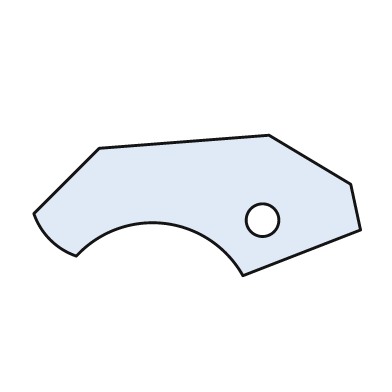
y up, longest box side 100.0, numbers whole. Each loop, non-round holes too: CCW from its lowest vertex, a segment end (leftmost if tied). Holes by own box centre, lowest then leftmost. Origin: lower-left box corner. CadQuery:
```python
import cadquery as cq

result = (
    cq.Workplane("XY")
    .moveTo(64.0, 0.0)
    .lineTo(100.0, 14.0)
    .lineTo(97.0, 28.0)
    .lineTo(72.0, 43.0)
    .lineTo(20.0, 39.0)
    .lineTo(0.0, 19.0)
    .threePointArc((5.0, 11.0), (13.0, 6.0))
    .threePointArc((40.0, 16.0), (64.0, 0.0))
    .close()
    .moveTo(70.0, 17.0)
    .circle(5.0)
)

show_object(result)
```